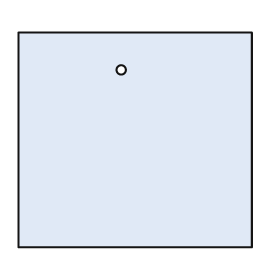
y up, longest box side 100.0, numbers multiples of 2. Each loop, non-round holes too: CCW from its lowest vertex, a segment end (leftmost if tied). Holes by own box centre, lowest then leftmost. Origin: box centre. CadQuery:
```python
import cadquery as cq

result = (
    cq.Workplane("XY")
    .moveTo(-50.0, -46.0)
    .lineTo(50.0, -46.0)
    .lineTo(50.0, 46.0)
    .lineTo(-50.0, 46.0)
    .close()
    .moveTo(-6.0, 30.0)
    .circle(2.0)
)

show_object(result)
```